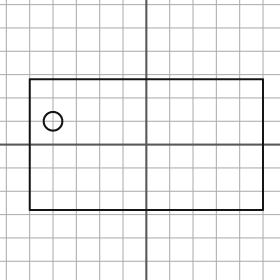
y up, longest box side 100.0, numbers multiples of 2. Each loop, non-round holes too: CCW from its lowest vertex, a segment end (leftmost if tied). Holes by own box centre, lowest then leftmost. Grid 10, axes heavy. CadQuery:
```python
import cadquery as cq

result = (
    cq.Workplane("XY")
    .moveTo(-50.0, -28.0)
    .lineTo(50.0, -28.0)
    .lineTo(50.0, 28.0)
    .lineTo(-50.0, 28.0)
    .close()
    .moveTo(-40.0, 10.0)
    .circle(4.0)
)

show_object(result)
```